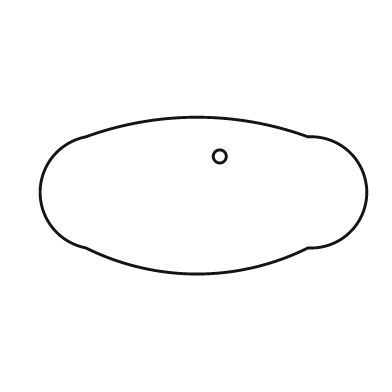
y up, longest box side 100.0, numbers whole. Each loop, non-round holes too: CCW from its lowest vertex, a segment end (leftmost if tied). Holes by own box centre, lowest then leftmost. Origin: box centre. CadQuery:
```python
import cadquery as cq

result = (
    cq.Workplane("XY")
    .moveTo(-36.0, -16.0)
    .threePointArc((-2.0, -24.0), (32.0, -16.0))
    .threePointArc((50.0, 1.0), (32.0, 18.0))
    .threePointArc((-2.0, 24.0), (-36.0, 18.0))
    .threePointArc((-50.0, 1.0), (-36.0, -16.0))
    .close()
    .moveTo(5.0, 12.0)
    .circle(2.0)
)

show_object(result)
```